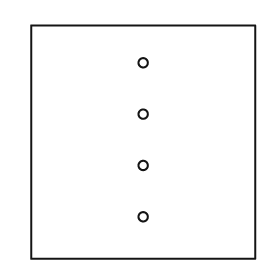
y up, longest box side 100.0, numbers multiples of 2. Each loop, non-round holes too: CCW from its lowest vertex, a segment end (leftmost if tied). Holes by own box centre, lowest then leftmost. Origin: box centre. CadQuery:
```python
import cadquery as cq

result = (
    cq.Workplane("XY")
    .moveTo(-48.0, -50.0)
    .lineTo(48.0, -50.0)
    .lineTo(48.0, 50.0)
    .lineTo(-48.0, 50.0)
    .close()
    .moveTo(0.0, -32.0)
    .circle(2.0)
    .moveTo(0.0, -10.0)
    .circle(2.0)
    .moveTo(0.0, 12.0)
    .circle(2.0)
    .moveTo(0.0, 34.0)
    .circle(2.0)
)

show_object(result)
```